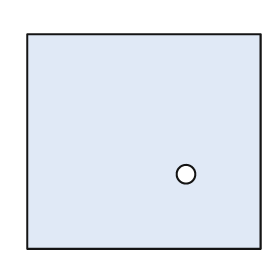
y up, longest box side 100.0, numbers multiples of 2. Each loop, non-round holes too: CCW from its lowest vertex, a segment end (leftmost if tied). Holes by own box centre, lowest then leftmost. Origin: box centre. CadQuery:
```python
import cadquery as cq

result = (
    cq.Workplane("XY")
    .moveTo(-50.0, -46.0)
    .lineTo(50.0, -46.0)
    .lineTo(50.0, 46.0)
    .lineTo(-50.0, 46.0)
    .close()
    .moveTo(18.0, -14.0)
    .circle(4.0)
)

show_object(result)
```